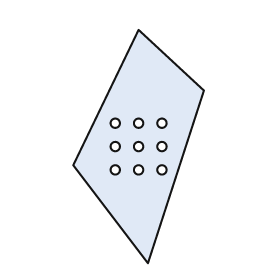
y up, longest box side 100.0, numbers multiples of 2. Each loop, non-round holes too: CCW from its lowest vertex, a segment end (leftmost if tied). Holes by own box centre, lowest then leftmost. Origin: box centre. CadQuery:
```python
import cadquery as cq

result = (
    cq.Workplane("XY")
    .moveTo(4.0, -50.0)
    .lineTo(28.0, 24.0)
    .lineTo(0.0, 50.0)
    .lineTo(-28.0, -8.0)
    .close()
    .moveTo(-10.0, -10.0)
    .circle(2.0)
    .moveTo(0.0, -10.0)
    .circle(2.0)
    .moveTo(10.0, -10.0)
    .circle(2.0)
    .moveTo(-10.0, 0.0)
    .circle(2.0)
    .moveTo(0.0, 0.0)
    .circle(2.0)
    .moveTo(10.0, 0.0)
    .circle(2.0)
    .moveTo(-10.0, 10.0)
    .circle(2.0)
    .moveTo(0.0, 10.0)
    .circle(2.0)
    .moveTo(10.0, 10.0)
    .circle(2.0)
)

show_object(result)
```